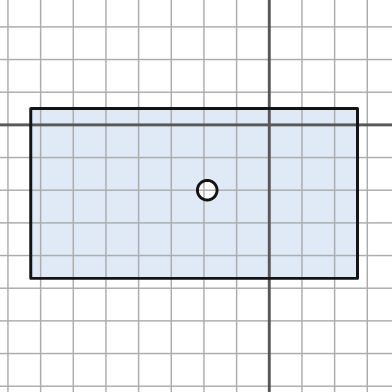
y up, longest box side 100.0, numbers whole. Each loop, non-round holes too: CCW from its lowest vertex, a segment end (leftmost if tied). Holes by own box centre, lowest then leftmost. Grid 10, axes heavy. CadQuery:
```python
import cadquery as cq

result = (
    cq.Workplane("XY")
    .moveTo(-73.0, -47.0)
    .lineTo(27.0, -47.0)
    .lineTo(27.0, 5.0)
    .lineTo(-73.0, 5.0)
    .close()
    .moveTo(-19.0, -20.0)
    .circle(3.0)
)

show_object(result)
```